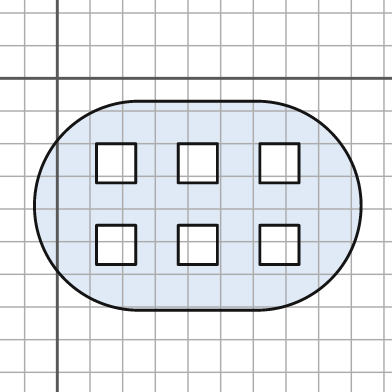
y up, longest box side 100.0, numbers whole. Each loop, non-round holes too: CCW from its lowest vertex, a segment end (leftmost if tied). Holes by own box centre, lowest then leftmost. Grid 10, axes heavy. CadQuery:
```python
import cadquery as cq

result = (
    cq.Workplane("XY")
    .moveTo(25.0, -71.0)
    .lineTo(61.0, -71.0)
    .threePointArc((93.0, -39.0), (61.0, -7.0))
    .lineTo(25.0, -7.0)
    .threePointArc((-7.0, -39.0), (25.0, -71.0))
    .close()
    .moveTo(12.0, -57.0)
    .lineTo(24.0, -57.0)
    .lineTo(24.0, -45.0)
    .lineTo(12.0, -45.0)
    .close()
    .moveTo(37.0, -57.0)
    .lineTo(49.0, -57.0)
    .lineTo(49.0, -45.0)
    .lineTo(37.0, -45.0)
    .close()
    .moveTo(62.0, -57.0)
    .lineTo(74.0, -57.0)
    .lineTo(74.0, -45.0)
    .lineTo(62.0, -45.0)
    .close()
    .moveTo(12.0, -32.0)
    .lineTo(24.0, -32.0)
    .lineTo(24.0, -20.0)
    .lineTo(12.0, -20.0)
    .close()
    .moveTo(37.0, -32.0)
    .lineTo(49.0, -32.0)
    .lineTo(49.0, -20.0)
    .lineTo(37.0, -20.0)
    .close()
    .moveTo(62.0, -32.0)
    .lineTo(74.0, -32.0)
    .lineTo(74.0, -20.0)
    .lineTo(62.0, -20.0)
    .close()
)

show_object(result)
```